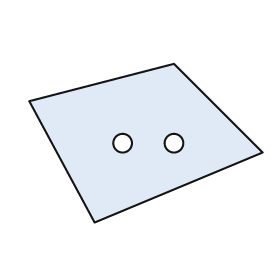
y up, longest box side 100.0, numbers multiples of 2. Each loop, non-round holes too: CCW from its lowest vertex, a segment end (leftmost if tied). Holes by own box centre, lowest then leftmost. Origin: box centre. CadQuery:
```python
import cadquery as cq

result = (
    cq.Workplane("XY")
    .moveTo(-22.0, -34.0)
    .lineTo(50.0, -4.0)
    .lineTo(12.0, 34.0)
    .lineTo(-50.0, 18.0)
    .close()
    .moveTo(-10.0, 0.0)
    .circle(4.0)
    .moveTo(12.0, 0.0)
    .circle(4.0)
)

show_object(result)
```